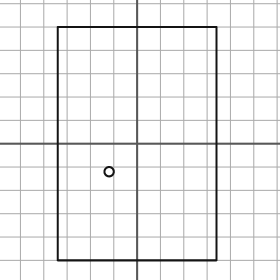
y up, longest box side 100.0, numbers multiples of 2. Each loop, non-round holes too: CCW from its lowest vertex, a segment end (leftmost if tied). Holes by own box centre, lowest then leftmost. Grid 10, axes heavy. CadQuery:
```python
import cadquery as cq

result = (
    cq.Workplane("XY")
    .moveTo(-34.0, -50.0)
    .lineTo(34.0, -50.0)
    .lineTo(34.0, 50.0)
    .lineTo(-34.0, 50.0)
    .close()
    .moveTo(-12.0, -12.0)
    .circle(2.0)
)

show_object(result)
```